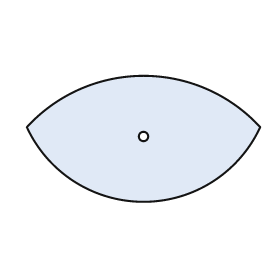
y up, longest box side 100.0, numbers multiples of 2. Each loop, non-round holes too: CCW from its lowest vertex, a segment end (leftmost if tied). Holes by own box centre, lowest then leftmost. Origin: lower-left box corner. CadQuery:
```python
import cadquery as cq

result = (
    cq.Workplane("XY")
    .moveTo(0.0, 32.0)
    .threePointArc((50.0, 0.0), (100.0, 32.0))
    .threePointArc((50.0, 54.0), (0.0, 32.0))
    .close()
    .moveTo(50.0, 28.0)
    .circle(2.0)
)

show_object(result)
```